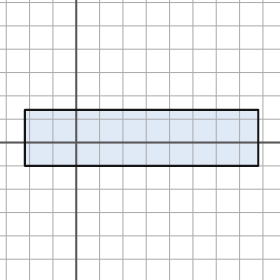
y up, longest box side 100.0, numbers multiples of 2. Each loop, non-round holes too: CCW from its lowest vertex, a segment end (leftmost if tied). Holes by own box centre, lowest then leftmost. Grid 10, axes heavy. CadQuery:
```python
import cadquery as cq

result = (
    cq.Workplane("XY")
    .moveTo(-22.0, -10.0)
    .lineTo(78.0, -10.0)
    .lineTo(78.0, 14.0)
    .lineTo(-22.0, 14.0)
    .close()
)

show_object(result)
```